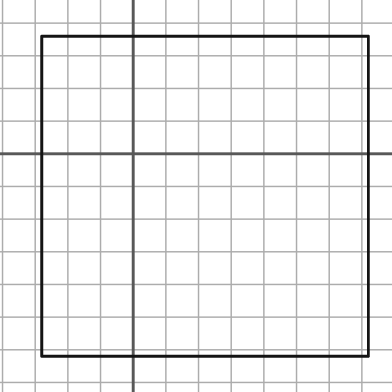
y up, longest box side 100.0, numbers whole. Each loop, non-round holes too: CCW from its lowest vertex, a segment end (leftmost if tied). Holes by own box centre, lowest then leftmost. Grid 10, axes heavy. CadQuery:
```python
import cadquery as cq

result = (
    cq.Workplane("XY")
    .moveTo(-28.0, -62.0)
    .lineTo(72.0, -62.0)
    .lineTo(72.0, 36.0)
    .lineTo(-28.0, 36.0)
    .close()
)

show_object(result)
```